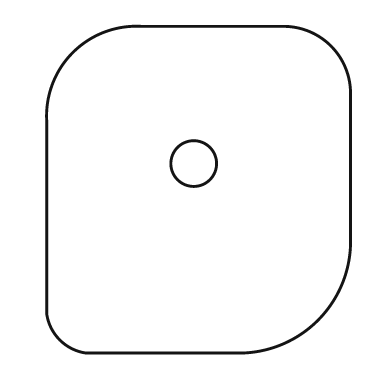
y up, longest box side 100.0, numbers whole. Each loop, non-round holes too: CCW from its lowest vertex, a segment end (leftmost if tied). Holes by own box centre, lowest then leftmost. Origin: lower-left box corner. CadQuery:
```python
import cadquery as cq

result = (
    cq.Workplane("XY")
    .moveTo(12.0, 0.0)
    .lineTo(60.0, 0.0)
    .threePointArc((83.0, 10.0), (93.0, 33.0))
    .lineTo(93.0, 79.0)
    .threePointArc((87.0, 94.0), (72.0, 100.0))
    .lineTo(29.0, 100.0)
    .threePointArc((8.0, 92.0), (0.0, 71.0))
    .lineTo(0.0, 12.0)
    .threePointArc((4.0, 4.0), (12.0, 0.0))
    .close()
    .moveTo(45.0, 58.0)
    .circle(7.0)
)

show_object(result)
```